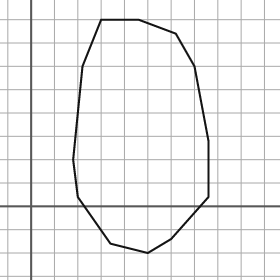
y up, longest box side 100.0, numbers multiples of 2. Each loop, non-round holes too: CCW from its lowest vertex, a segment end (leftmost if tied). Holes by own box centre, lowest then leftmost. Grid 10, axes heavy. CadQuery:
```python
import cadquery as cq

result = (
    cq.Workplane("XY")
    .moveTo(50.0, -20.0)
    .lineTo(60.0, -14.0)
    .lineTo(76.0, 4.0)
    .lineTo(76.0, 28.0)
    .lineTo(70.0, 60.0)
    .lineTo(62.0, 74.0)
    .lineTo(46.0, 80.0)
    .lineTo(30.0, 80.0)
    .lineTo(22.0, 60.0)
    .lineTo(18.0, 20.0)
    .lineTo(20.0, 4.0)
    .lineTo(34.0, -16.0)
    .close()
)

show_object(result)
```